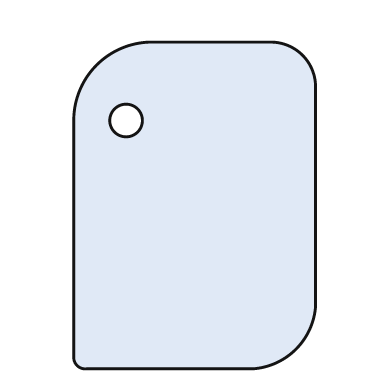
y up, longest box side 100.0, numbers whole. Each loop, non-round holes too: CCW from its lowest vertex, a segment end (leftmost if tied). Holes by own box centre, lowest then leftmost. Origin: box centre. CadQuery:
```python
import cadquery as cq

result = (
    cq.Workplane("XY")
    .moveTo(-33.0, -50.0)
    .lineTo(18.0, -50.0)
    .threePointArc((31.0, -44.0), (37.0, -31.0))
    .lineTo(37.0, 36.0)
    .threePointArc((33.0, 46.0), (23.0, 50.0))
    .lineTo(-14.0, 50.0)
    .threePointArc((-30.0, 43.0), (-37.0, 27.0))
    .lineTo(-37.0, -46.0)
    .threePointArc((-36.0, -49.0), (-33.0, -50.0))
    .close()
    .moveTo(-21.0, 26.0)
    .circle(5.0)
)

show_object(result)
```